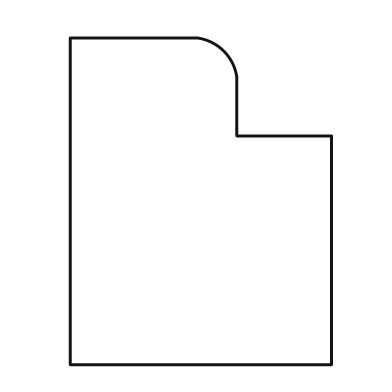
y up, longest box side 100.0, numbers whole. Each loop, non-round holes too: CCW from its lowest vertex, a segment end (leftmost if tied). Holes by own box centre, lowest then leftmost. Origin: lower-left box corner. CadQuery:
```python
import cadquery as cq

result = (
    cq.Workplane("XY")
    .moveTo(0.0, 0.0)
    .lineTo(80.0, 0.0)
    .lineTo(80.0, 70.0)
    .lineTo(51.0, 70.0)
    .lineTo(51.0, 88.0)
    .threePointArc((47.0, 96.0), (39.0, 100.0))
    .lineTo(0.0, 100.0)
    .close()
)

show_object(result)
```